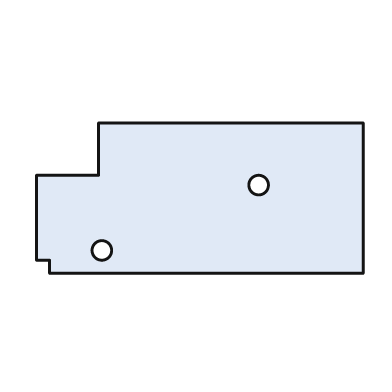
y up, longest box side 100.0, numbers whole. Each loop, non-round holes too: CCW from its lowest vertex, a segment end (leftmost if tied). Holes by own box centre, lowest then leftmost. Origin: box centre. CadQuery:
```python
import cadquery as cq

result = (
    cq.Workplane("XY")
    .moveTo(-46.0, -23.0)
    .lineTo(50.0, -23.0)
    .lineTo(50.0, 23.0)
    .lineTo(-31.0, 23.0)
    .lineTo(-31.0, 7.0)
    .lineTo(-50.0, 7.0)
    .lineTo(-50.0, -19.0)
    .lineTo(-46.0, -19.0)
    .close()
    .moveTo(-30.0, -16.0)
    .circle(3.0)
    .moveTo(18.0, 4.0)
    .circle(3.0)
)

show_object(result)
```